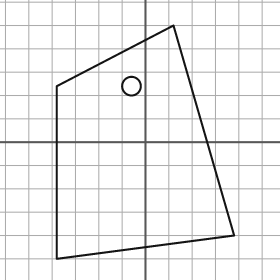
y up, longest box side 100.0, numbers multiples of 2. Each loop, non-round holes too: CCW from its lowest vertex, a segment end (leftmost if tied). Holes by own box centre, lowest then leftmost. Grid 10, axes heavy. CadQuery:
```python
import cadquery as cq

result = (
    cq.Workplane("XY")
    .moveTo(-38.0, -50.0)
    .lineTo(38.0, -40.0)
    .lineTo(12.0, 50.0)
    .lineTo(-38.0, 24.0)
    .close()
    .moveTo(-6.0, 24.0)
    .circle(4.0)
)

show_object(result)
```